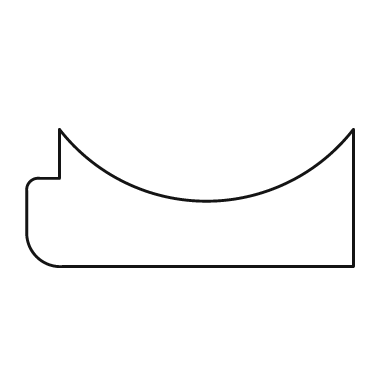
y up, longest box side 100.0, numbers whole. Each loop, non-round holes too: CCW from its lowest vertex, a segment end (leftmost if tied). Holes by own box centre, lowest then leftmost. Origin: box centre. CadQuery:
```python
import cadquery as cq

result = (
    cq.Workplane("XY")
    .moveTo(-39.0, -21.0)
    .lineTo(50.0, -21.0)
    .lineTo(50.0, 21.0)
    .threePointArc((5.0, -1.0), (-40.0, 21.0))
    .lineTo(-40.0, 6.0)
    .lineTo(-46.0, 6.0)
    .threePointArc((-49.0, 5.0), (-50.0, 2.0))
    .lineTo(-50.0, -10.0)
    .threePointArc((-47.0, -18.0), (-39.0, -21.0))
    .close()
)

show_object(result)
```